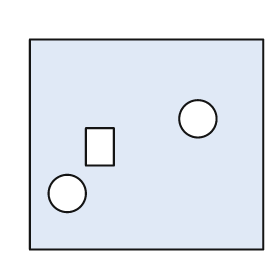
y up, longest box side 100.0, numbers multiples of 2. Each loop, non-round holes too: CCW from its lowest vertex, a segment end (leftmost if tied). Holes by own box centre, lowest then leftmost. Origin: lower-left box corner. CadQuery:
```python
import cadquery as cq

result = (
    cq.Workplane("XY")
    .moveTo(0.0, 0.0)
    .lineTo(100.0, 0.0)
    .lineTo(100.0, 90.0)
    .lineTo(0.0, 90.0)
    .close()
    .moveTo(16.0, 24.0)
    .circle(8.0)
    .moveTo(24.0, 36.0)
    .lineTo(36.0, 36.0)
    .lineTo(36.0, 52.0)
    .lineTo(24.0, 52.0)
    .close()
    .moveTo(72.0, 56.0)
    .circle(8.0)
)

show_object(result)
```